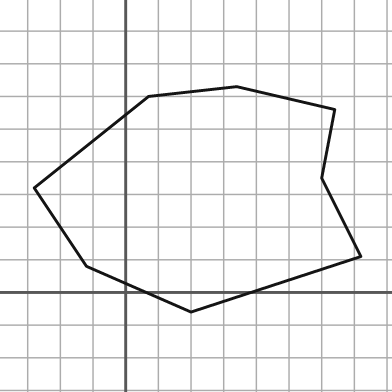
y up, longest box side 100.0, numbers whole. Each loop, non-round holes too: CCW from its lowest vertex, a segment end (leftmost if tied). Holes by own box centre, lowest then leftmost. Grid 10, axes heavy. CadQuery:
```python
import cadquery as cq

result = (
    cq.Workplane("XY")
    .moveTo(20.0, -6.0)
    .lineTo(72.0, 11.0)
    .lineTo(60.0, 35.0)
    .lineTo(64.0, 56.0)
    .lineTo(34.0, 63.0)
    .lineTo(7.0, 60.0)
    .lineTo(-28.0, 32.0)
    .lineTo(-12.0, 8.0)
    .close()
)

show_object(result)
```